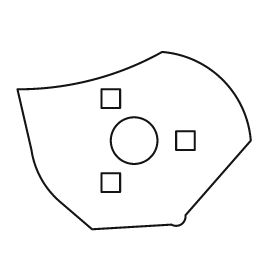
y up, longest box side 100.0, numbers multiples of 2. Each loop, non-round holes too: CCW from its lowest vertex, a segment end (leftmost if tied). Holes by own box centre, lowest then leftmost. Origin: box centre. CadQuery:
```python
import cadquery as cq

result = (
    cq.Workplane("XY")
    .moveTo(-18.0, -38.0)
    .lineTo(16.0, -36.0)
    .threePointArc((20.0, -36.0), (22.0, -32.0))
    .lineTo(50.0, 0.0)
    .threePointArc((38.0, 26.0), (12.0, 38.0))
    .threePointArc((-18.0, 26.0), (-50.0, 22.0))
    .lineTo(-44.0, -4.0)
    .threePointArc((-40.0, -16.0), (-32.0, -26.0))
    .close()
    .moveTo(-14.0, -22.0)
    .lineTo(-6.0, -22.0)
    .lineTo(-6.0, -14.0)
    .lineTo(-14.0, -14.0)
    .close()
    .moveTo(0.0, 0.0)
    .circle(10.0)
    .moveTo(18.0, -4.0)
    .lineTo(26.0, -4.0)
    .lineTo(26.0, 4.0)
    .lineTo(18.0, 4.0)
    .close()
    .moveTo(-14.0, 14.0)
    .lineTo(-6.0, 14.0)
    .lineTo(-6.0, 22.0)
    .lineTo(-14.0, 22.0)
    .close()
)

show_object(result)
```